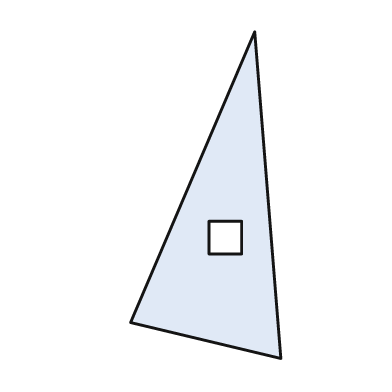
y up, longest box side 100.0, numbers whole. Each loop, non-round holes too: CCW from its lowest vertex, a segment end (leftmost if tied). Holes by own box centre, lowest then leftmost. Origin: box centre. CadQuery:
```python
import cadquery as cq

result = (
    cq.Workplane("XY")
    .moveTo(23.0, -50.0)
    .lineTo(15.0, 50.0)
    .lineTo(-23.0, -39.0)
    .close()
    .moveTo(1.0, -18.0)
    .lineTo(11.0, -18.0)
    .lineTo(11.0, -8.0)
    .lineTo(1.0, -8.0)
    .close()
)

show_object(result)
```